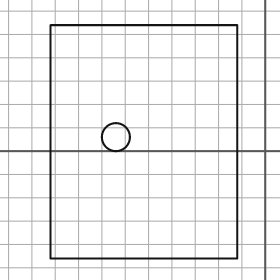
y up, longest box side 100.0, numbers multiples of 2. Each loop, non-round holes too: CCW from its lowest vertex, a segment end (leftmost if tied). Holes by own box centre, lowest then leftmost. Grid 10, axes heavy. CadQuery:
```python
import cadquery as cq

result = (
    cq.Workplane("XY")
    .moveTo(-92.0, -46.0)
    .lineTo(-12.0, -46.0)
    .lineTo(-12.0, 54.0)
    .lineTo(-92.0, 54.0)
    .close()
    .moveTo(-64.0, 6.0)
    .circle(6.0)
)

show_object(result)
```